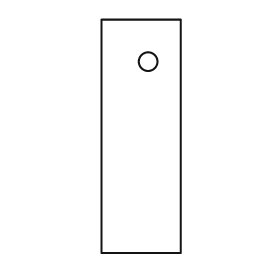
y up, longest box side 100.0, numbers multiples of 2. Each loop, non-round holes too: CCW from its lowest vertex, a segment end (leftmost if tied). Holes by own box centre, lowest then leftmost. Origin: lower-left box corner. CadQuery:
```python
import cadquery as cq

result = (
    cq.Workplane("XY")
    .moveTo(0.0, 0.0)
    .lineTo(34.0, 0.0)
    .lineTo(34.0, 100.0)
    .lineTo(0.0, 100.0)
    .close()
    .moveTo(20.0, 82.0)
    .circle(4.0)
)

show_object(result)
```